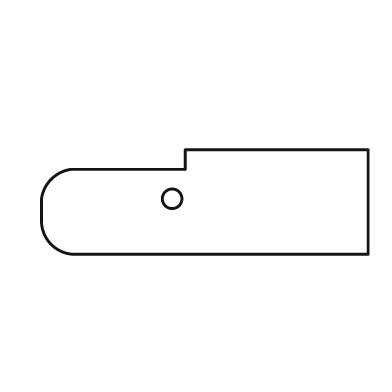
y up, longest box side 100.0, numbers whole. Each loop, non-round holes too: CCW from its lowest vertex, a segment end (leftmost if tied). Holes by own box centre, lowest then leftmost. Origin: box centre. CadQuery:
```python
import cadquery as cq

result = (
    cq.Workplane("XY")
    .moveTo(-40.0, -16.0)
    .lineTo(50.0, -16.0)
    .lineTo(50.0, 16.0)
    .lineTo(-6.0, 16.0)
    .lineTo(-6.0, 10.0)
    .lineTo(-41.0, 10.0)
    .threePointArc((-47.0, 7.0), (-50.0, 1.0))
    .lineTo(-50.0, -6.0)
    .threePointArc((-47.0, -13.0), (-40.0, -16.0))
    .close()
    .moveTo(-10.0, 1.0)
    .circle(3.0)
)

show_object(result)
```